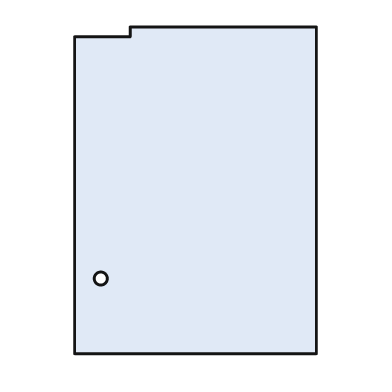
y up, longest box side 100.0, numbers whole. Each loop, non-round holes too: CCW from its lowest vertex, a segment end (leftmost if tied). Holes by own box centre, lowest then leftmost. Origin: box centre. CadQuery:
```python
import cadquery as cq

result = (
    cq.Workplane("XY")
    .moveTo(-37.0, -50.0)
    .lineTo(37.0, -50.0)
    .lineTo(37.0, 50.0)
    .lineTo(-20.0, 50.0)
    .lineTo(-20.0, 47.0)
    .lineTo(-37.0, 47.0)
    .close()
    .moveTo(-29.0, -27.0)
    .circle(2.0)
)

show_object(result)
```